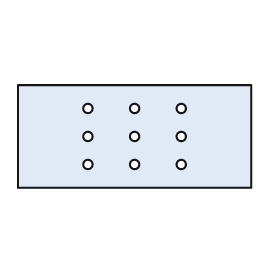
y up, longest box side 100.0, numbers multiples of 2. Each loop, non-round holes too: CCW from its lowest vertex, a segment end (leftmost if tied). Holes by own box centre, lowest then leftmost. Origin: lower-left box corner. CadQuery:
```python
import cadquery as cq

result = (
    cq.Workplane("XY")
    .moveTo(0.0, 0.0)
    .lineTo(100.0, 0.0)
    .lineTo(100.0, 44.0)
    .lineTo(0.0, 44.0)
    .close()
    .moveTo(30.0, 10.0)
    .circle(2.0)
    .moveTo(50.0, 10.0)
    .circle(2.0)
    .moveTo(70.0, 10.0)
    .circle(2.0)
    .moveTo(30.0, 22.0)
    .circle(2.0)
    .moveTo(50.0, 22.0)
    .circle(2.0)
    .moveTo(70.0, 22.0)
    .circle(2.0)
    .moveTo(30.0, 34.0)
    .circle(2.0)
    .moveTo(50.0, 34.0)
    .circle(2.0)
    .moveTo(70.0, 34.0)
    .circle(2.0)
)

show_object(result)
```